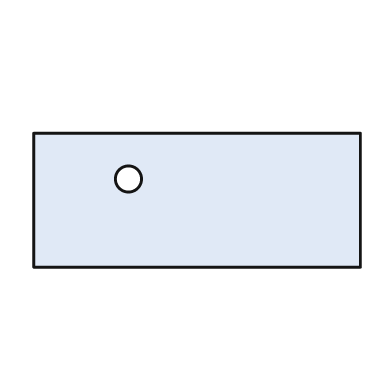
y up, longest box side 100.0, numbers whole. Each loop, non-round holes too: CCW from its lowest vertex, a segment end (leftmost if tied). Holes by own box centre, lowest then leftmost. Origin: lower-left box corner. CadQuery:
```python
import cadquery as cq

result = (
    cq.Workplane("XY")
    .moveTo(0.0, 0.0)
    .lineTo(100.0, 0.0)
    .lineTo(100.0, 41.0)
    .lineTo(0.0, 41.0)
    .close()
    .moveTo(29.0, 27.0)
    .circle(4.0)
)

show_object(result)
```